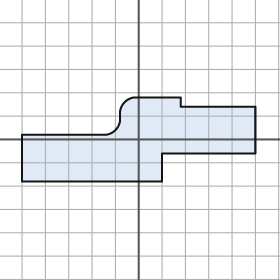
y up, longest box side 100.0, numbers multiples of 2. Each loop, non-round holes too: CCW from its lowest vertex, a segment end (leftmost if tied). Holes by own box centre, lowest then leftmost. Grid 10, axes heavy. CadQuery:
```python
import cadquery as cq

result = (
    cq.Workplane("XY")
    .moveTo(-50.0, -18.0)
    .lineTo(10.0, -18.0)
    .lineTo(10.0, -6.0)
    .lineTo(50.0, -6.0)
    .lineTo(50.0, 14.0)
    .lineTo(18.0, 14.0)
    .lineTo(18.0, 18.0)
    .lineTo(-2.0, 18.0)
    .threePointArc((-6.0, 16.0), (-8.0, 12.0))
    .lineTo(-8.0, 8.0)
    .threePointArc((-10.0, 4.0), (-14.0, 2.0))
    .lineTo(-50.0, 2.0)
    .close()
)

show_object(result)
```